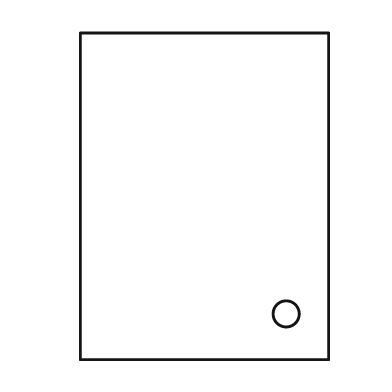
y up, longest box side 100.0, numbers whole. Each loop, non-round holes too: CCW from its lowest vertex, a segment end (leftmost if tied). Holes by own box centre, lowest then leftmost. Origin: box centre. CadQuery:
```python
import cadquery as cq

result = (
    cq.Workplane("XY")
    .moveTo(-38.0, -50.0)
    .lineTo(38.0, -50.0)
    .lineTo(38.0, 50.0)
    .lineTo(-38.0, 50.0)
    .close()
    .moveTo(25.0, -36.0)
    .circle(4.0)
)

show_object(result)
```